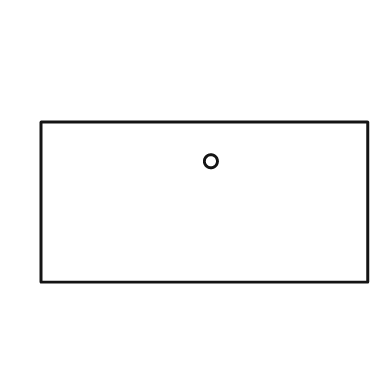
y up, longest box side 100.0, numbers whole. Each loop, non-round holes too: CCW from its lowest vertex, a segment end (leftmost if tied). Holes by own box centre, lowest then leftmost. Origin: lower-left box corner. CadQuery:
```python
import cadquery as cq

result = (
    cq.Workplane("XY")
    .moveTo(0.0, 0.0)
    .lineTo(100.0, 0.0)
    .lineTo(100.0, 49.0)
    .lineTo(0.0, 49.0)
    .close()
    .moveTo(52.0, 37.0)
    .circle(2.0)
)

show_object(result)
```